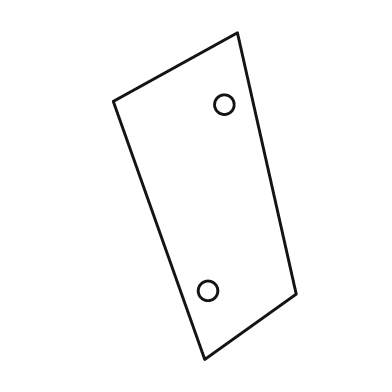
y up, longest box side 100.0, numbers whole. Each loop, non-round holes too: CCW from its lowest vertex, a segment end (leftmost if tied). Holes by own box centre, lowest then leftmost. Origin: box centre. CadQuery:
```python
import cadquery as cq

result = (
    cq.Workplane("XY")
    .moveTo(0.0, -50.0)
    .lineTo(28.0, -30.0)
    .lineTo(10.0, 50.0)
    .lineTo(-28.0, 29.0)
    .close()
    .moveTo(1.0, -29.0)
    .circle(3.0)
    .moveTo(6.0, 28.0)
    .circle(3.0)
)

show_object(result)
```